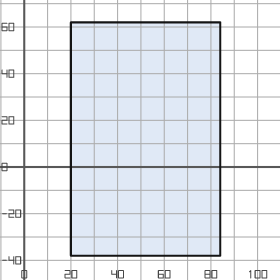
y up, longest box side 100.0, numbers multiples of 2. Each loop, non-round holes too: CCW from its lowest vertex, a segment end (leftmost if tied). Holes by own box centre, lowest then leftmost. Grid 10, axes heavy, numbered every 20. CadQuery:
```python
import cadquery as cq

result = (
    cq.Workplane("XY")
    .moveTo(20.0, -38.0)
    .lineTo(84.0, -38.0)
    .lineTo(84.0, 62.0)
    .lineTo(20.0, 62.0)
    .close()
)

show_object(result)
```